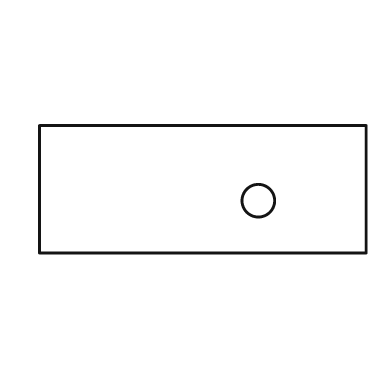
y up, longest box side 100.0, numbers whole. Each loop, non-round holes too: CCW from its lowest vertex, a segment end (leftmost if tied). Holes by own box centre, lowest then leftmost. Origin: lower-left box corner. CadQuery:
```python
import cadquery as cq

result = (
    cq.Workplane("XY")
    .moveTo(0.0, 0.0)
    .lineTo(100.0, 0.0)
    .lineTo(100.0, 39.0)
    .lineTo(0.0, 39.0)
    .close()
    .moveTo(67.0, 16.0)
    .circle(5.0)
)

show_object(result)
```